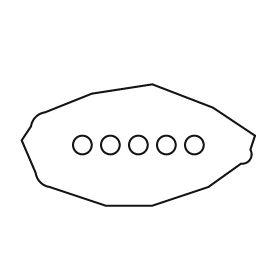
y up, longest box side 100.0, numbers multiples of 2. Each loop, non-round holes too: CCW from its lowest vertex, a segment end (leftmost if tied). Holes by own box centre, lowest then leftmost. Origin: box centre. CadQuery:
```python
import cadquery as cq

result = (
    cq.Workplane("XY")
    .moveTo(-14.0, -26.0)
    .lineTo(6.0, -26.0)
    .lineTo(30.0, -18.0)
    .lineTo(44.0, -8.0)
    .threePointArc((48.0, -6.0), (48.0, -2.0))
    .lineTo(50.0, 4.0)
    .lineTo(32.0, 16.0)
    .lineTo(6.0, 26.0)
    .lineTo(-20.0, 22.0)
    .lineTo(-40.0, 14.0)
    .threePointArc((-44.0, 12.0), (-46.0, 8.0))
    .lineTo(-50.0, 2.0)
    .lineTo(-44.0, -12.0)
    .threePointArc((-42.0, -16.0), (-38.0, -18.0))
    .close()
    .moveTo(-24.0, 0.0)
    .circle(4.0)
    .moveTo(-12.0, 0.0)
    .circle(4.0)
    .moveTo(0.0, 0.0)
    .circle(4.0)
    .moveTo(12.0, 0.0)
    .circle(4.0)
    .moveTo(24.0, 0.0)
    .circle(4.0)
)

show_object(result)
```